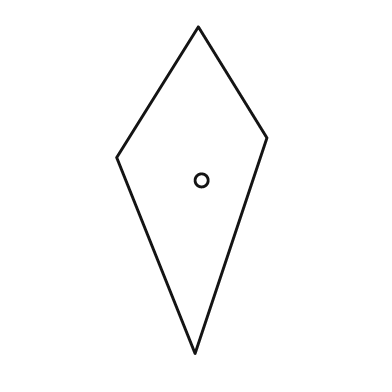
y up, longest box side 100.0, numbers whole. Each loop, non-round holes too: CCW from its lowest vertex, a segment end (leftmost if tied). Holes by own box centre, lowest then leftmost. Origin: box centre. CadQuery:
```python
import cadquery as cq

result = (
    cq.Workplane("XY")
    .moveTo(1.0, -50.0)
    .lineTo(23.0, 16.0)
    .lineTo(2.0, 50.0)
    .lineTo(-23.0, 10.0)
    .close()
    .moveTo(3.0, 3.0)
    .circle(2.0)
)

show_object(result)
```